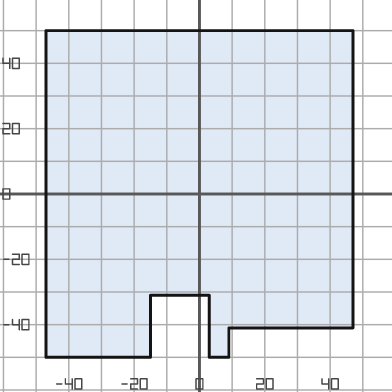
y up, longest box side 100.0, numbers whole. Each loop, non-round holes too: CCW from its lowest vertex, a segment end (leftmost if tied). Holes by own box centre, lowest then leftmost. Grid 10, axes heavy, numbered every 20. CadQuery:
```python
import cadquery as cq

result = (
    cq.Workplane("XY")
    .moveTo(-47.0, -50.0)
    .lineTo(-15.0, -50.0)
    .lineTo(-15.0, -31.0)
    .lineTo(3.0, -31.0)
    .lineTo(3.0, -50.0)
    .lineTo(9.0, -50.0)
    .lineTo(9.0, -41.0)
    .lineTo(47.0, -41.0)
    .lineTo(47.0, 50.0)
    .lineTo(-47.0, 50.0)
    .close()
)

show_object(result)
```